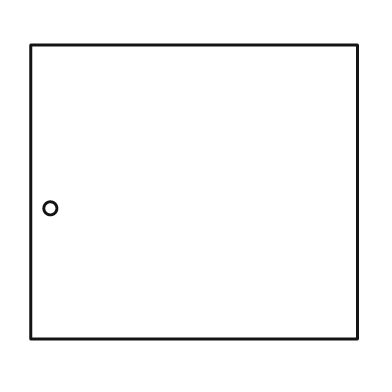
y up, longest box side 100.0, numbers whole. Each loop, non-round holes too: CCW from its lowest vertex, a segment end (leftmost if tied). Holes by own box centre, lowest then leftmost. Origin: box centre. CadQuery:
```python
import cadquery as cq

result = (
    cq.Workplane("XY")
    .moveTo(-50.0, -45.0)
    .lineTo(50.0, -45.0)
    .lineTo(50.0, 45.0)
    .lineTo(-50.0, 45.0)
    .close()
    .moveTo(-44.0, -5.0)
    .circle(2.0)
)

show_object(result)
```